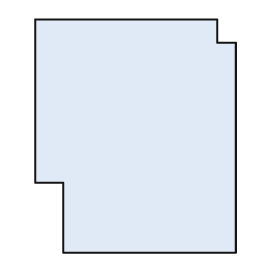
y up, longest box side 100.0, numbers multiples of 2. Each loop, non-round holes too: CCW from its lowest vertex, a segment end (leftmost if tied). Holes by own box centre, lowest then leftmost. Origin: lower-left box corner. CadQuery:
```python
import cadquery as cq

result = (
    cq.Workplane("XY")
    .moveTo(12.0, 0.0)
    .lineTo(86.0, 0.0)
    .lineTo(86.0, 90.0)
    .lineTo(78.0, 90.0)
    .lineTo(78.0, 100.0)
    .lineTo(0.0, 100.0)
    .lineTo(0.0, 30.0)
    .lineTo(12.0, 30.0)
    .close()
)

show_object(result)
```